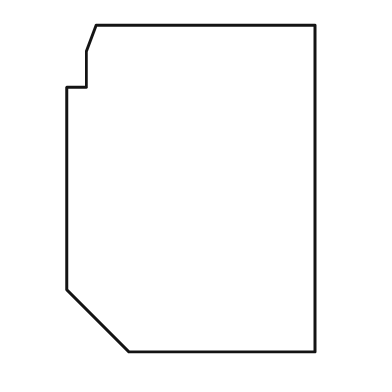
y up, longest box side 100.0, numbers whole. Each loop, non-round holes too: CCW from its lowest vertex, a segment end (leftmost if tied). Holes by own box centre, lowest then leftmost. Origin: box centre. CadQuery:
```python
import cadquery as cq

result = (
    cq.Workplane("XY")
    .moveTo(-19.0, -50.0)
    .lineTo(38.0, -50.0)
    .lineTo(38.0, 50.0)
    .lineTo(-29.0, 50.0)
    .lineTo(-32.0, 42.0)
    .lineTo(-32.0, 31.0)
    .lineTo(-38.0, 31.0)
    .lineTo(-38.0, -31.0)
    .close()
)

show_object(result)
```